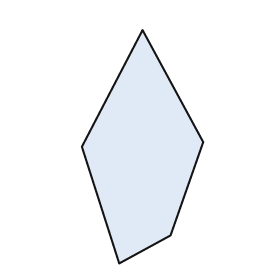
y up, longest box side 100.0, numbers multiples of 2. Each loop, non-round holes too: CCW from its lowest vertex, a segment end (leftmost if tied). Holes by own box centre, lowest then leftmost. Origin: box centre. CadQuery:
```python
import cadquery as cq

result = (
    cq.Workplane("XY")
    .moveTo(-10.0, -50.0)
    .lineTo(12.0, -38.0)
    .lineTo(26.0, 2.0)
    .lineTo(0.0, 50.0)
    .lineTo(-26.0, 0.0)
    .close()
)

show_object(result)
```